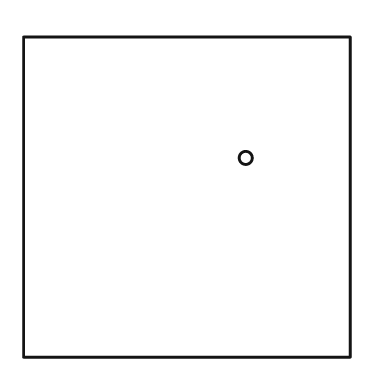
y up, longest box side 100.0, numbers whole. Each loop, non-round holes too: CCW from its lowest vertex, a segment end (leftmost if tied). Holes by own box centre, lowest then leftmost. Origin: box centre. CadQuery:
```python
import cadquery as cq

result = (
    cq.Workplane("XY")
    .moveTo(-50.0, -49.0)
    .lineTo(50.0, -49.0)
    .lineTo(50.0, 49.0)
    .lineTo(-50.0, 49.0)
    .close()
    .moveTo(18.0, 12.0)
    .circle(2.0)
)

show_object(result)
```